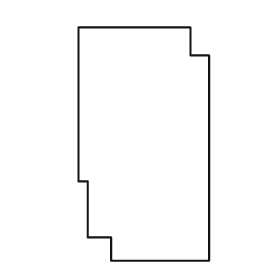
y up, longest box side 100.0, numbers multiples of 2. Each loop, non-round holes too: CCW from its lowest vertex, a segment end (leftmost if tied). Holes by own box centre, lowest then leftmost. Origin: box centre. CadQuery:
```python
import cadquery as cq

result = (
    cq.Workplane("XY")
    .moveTo(-14.0, -50.0)
    .lineTo(28.0, -50.0)
    .lineTo(28.0, 38.0)
    .lineTo(20.0, 38.0)
    .lineTo(20.0, 50.0)
    .lineTo(-28.0, 50.0)
    .lineTo(-28.0, -16.0)
    .lineTo(-24.0, -16.0)
    .lineTo(-24.0, -40.0)
    .lineTo(-14.0, -40.0)
    .close()
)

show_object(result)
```